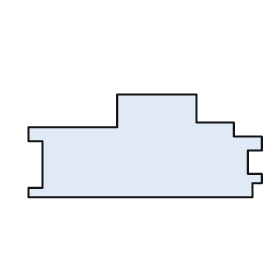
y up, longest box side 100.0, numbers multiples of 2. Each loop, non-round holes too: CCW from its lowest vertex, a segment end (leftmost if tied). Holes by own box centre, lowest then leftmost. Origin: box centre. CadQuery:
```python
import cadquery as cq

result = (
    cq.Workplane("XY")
    .moveTo(-50.0, -22.0)
    .lineTo(46.0, -22.0)
    .lineTo(46.0, -16.0)
    .lineTo(50.0, -16.0)
    .lineTo(50.0, -12.0)
    .lineTo(44.0, -12.0)
    .lineTo(44.0, -2.0)
    .lineTo(50.0, -2.0)
    .lineTo(50.0, 4.0)
    .lineTo(38.0, 4.0)
    .lineTo(38.0, 10.0)
    .lineTo(22.0, 10.0)
    .lineTo(22.0, 22.0)
    .lineTo(-12.0, 22.0)
    .lineTo(-12.0, 8.0)
    .lineTo(-50.0, 8.0)
    .lineTo(-50.0, 2.0)
    .lineTo(-44.0, 2.0)
    .lineTo(-44.0, -18.0)
    .lineTo(-50.0, -18.0)
    .close()
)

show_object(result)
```